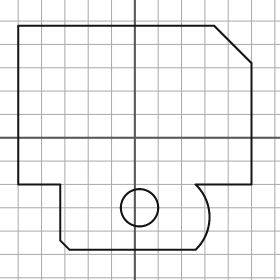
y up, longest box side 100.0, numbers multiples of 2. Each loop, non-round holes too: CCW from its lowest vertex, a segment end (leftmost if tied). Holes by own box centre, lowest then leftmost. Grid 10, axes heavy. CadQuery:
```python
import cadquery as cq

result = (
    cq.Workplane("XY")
    .moveTo(-28.0, -48.0)
    .lineTo(26.0, -48.0)
    .threePointArc((32.0, -34.0), (26.0, -20.0))
    .lineTo(50.0, -20.0)
    .lineTo(50.0, 32.0)
    .lineTo(34.0, 48.0)
    .lineTo(-50.0, 48.0)
    .lineTo(-50.0, -20.0)
    .lineTo(-32.0, -20.0)
    .lineTo(-32.0, -44.0)
    .close()
    .moveTo(2.0, -30.0)
    .circle(8.0)
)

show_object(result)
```